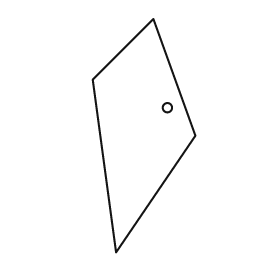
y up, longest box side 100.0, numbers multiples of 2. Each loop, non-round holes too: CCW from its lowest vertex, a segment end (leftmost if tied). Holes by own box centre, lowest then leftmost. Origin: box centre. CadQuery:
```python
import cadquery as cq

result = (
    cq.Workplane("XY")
    .moveTo(-12.0, -50.0)
    .lineTo(22.0, 0.0)
    .lineTo(4.0, 50.0)
    .lineTo(-22.0, 24.0)
    .close()
    .moveTo(10.0, 12.0)
    .circle(2.0)
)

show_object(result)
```